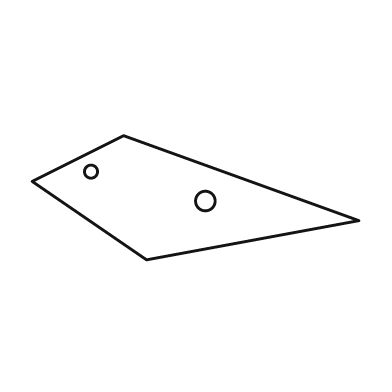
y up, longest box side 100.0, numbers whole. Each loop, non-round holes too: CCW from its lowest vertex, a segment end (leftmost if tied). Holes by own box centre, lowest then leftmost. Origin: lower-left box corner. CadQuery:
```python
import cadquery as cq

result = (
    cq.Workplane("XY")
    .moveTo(35.0, 0.0)
    .lineTo(100.0, 12.0)
    .lineTo(28.0, 38.0)
    .lineTo(0.0, 24.0)
    .close()
    .moveTo(53.0, 18.0)
    .circle(3.0)
    .moveTo(18.0, 27.0)
    .circle(2.0)
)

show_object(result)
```